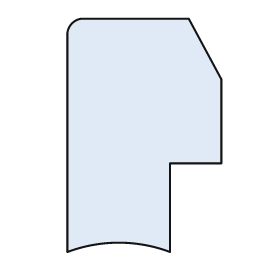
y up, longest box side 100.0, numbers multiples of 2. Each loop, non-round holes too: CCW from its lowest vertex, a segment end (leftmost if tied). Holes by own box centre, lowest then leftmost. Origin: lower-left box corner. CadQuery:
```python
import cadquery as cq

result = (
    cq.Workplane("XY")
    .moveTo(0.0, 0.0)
    .threePointArc((22.0, 4.0), (44.0, 0.0))
    .lineTo(44.0, 38.0)
    .lineTo(66.0, 38.0)
    .lineTo(66.0, 74.0)
    .lineTo(52.0, 100.0)
    .lineTo(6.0, 100.0)
    .threePointArc((2.0, 98.0), (0.0, 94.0))
    .close()
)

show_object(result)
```